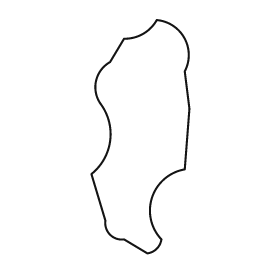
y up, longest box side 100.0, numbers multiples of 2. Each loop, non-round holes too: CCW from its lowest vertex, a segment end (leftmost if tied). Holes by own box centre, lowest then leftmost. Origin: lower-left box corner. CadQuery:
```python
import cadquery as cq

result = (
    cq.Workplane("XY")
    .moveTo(24.0, 0.0)
    .threePointArc((28.0, 2.0), (30.0, 6.0))
    .threePointArc((26.0, 24.0), (40.0, 36.0))
    .lineTo(42.0, 62.0)
    .lineTo(40.0, 78.0)
    .threePointArc((40.0, 92.0), (28.0, 100.0))
    .threePointArc((22.0, 94.0), (14.0, 92.0))
    .lineTo(8.0, 82.0)
    .threePointArc((2.0, 74.0), (4.0, 64.0))
    .threePointArc((8.0, 48.0), (0.0, 34.0))
    .lineTo(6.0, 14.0)
    .threePointArc((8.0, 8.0), (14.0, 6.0))
    .close()
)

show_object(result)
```